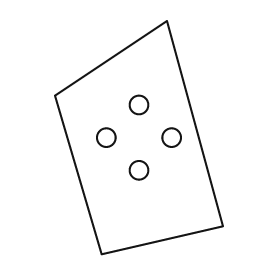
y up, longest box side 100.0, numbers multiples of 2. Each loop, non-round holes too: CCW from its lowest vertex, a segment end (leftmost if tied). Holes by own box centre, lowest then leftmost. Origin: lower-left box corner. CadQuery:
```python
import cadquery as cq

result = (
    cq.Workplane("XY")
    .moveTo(20.0, 0.0)
    .lineTo(72.0, 12.0)
    .lineTo(48.0, 100.0)
    .lineTo(0.0, 68.0)
    .close()
    .moveTo(36.0, 36.0)
    .circle(4.0)
    .moveTo(22.0, 50.0)
    .circle(4.0)
    .moveTo(50.0, 50.0)
    .circle(4.0)
    .moveTo(36.0, 64.0)
    .circle(4.0)
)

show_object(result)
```